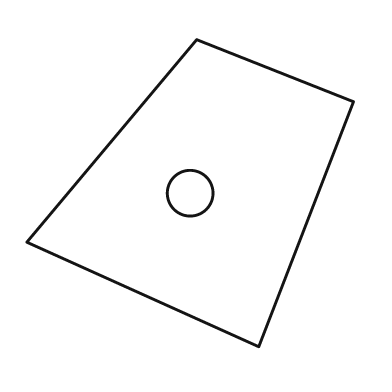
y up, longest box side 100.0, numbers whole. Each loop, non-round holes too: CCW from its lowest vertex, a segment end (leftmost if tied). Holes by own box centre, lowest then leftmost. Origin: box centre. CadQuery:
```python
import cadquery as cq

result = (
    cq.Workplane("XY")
    .moveTo(21.0, -47.0)
    .lineTo(50.0, 28.0)
    .lineTo(2.0, 47.0)
    .lineTo(-50.0, -15.0)
    .close()
    .moveTo(0.0, 0.0)
    .circle(7.0)
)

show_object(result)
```